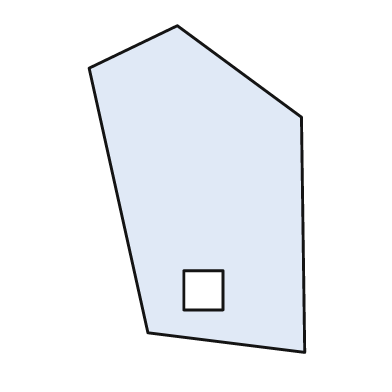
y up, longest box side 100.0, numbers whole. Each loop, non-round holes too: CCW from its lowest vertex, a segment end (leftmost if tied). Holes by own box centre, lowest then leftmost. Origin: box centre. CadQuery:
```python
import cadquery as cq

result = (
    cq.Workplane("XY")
    .moveTo(33.0, -50.0)
    .lineTo(32.0, 22.0)
    .lineTo(-6.0, 50.0)
    .lineTo(-33.0, 37.0)
    .lineTo(-15.0, -44.0)
    .close()
    .moveTo(-4.0, -37.0)
    .lineTo(8.0, -37.0)
    .lineTo(8.0, -25.0)
    .lineTo(-4.0, -25.0)
    .close()
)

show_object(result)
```